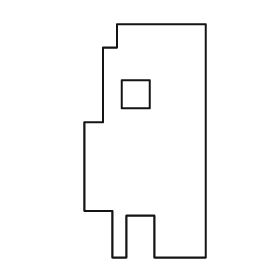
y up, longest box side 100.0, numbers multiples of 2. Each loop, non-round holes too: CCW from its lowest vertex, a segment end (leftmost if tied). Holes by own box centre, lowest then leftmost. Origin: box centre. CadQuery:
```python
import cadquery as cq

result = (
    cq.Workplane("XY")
    .moveTo(-14.0, -50.0)
    .lineTo(-8.0, -50.0)
    .lineTo(-8.0, -32.0)
    .lineTo(4.0, -32.0)
    .lineTo(4.0, -50.0)
    .lineTo(26.0, -50.0)
    .lineTo(26.0, 50.0)
    .lineTo(-12.0, 50.0)
    .lineTo(-12.0, 40.0)
    .lineTo(-18.0, 40.0)
    .lineTo(-18.0, 8.0)
    .lineTo(-26.0, 8.0)
    .lineTo(-26.0, -30.0)
    .lineTo(-14.0, -30.0)
    .close()
    .moveTo(-10.0, 14.0)
    .lineTo(2.0, 14.0)
    .lineTo(2.0, 26.0)
    .lineTo(-10.0, 26.0)
    .close()
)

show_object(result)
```